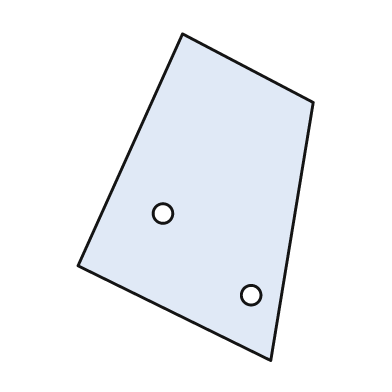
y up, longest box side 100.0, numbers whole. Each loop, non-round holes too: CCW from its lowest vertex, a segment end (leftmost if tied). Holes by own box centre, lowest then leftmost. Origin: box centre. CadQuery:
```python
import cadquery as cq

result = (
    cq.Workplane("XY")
    .moveTo(23.0, -50.0)
    .lineTo(36.0, 29.0)
    .lineTo(-4.0, 50.0)
    .lineTo(-36.0, -21.0)
    .close()
    .moveTo(17.0, -30.0)
    .circle(3.0)
    .moveTo(-10.0, -5.0)
    .circle(3.0)
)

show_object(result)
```